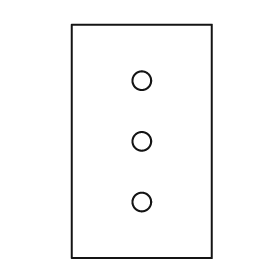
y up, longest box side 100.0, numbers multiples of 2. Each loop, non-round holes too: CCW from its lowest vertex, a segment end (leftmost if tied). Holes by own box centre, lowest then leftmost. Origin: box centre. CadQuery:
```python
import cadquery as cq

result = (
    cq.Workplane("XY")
    .moveTo(-30.0, -50.0)
    .lineTo(30.0, -50.0)
    .lineTo(30.0, 50.0)
    .lineTo(-30.0, 50.0)
    .close()
    .moveTo(0.0, -26.0)
    .circle(4.0)
    .moveTo(0.0, 0.0)
    .circle(4.0)
    .moveTo(0.0, 26.0)
    .circle(4.0)
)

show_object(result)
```